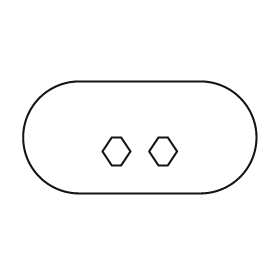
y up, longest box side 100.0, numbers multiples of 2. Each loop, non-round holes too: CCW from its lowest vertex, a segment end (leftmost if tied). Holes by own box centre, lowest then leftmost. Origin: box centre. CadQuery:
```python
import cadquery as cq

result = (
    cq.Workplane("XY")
    .moveTo(-26.0, -24.0)
    .lineTo(26.0, -24.0)
    .threePointArc((50.0, 0.0), (26.0, 24.0))
    .lineTo(-26.0, 24.0)
    .threePointArc((-50.0, 0.0), (-26.0, -24.0))
    .close()
    .moveTo(-12.0, -12.0)
    .lineTo(-8.0, -12.0)
    .lineTo(-4.0, -6.0)
    .lineTo(-8.0, 0.0)
    .lineTo(-12.0, 0.0)
    .lineTo(-16.0, -6.0)
    .close()
    .moveTo(8.0, -12.0)
    .lineTo(12.0, -12.0)
    .lineTo(16.0, -6.0)
    .lineTo(12.0, 0.0)
    .lineTo(8.0, 0.0)
    .lineTo(4.0, -6.0)
    .close()
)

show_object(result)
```